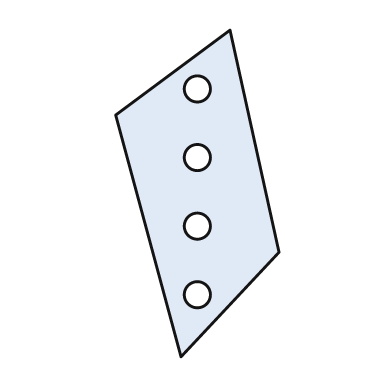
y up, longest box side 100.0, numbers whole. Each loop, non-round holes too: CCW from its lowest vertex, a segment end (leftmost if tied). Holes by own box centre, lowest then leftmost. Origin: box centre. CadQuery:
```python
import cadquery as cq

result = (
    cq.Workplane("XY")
    .moveTo(-5.0, -50.0)
    .lineTo(25.0, -18.0)
    .lineTo(10.0, 50.0)
    .lineTo(-25.0, 24.0)
    .close()
    .moveTo(0.0, -31.0)
    .circle(4.0)
    .moveTo(0.0, -10.0)
    .circle(4.0)
    .moveTo(0.0, 11.0)
    .circle(4.0)
    .moveTo(0.0, 32.0)
    .circle(4.0)
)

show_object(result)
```